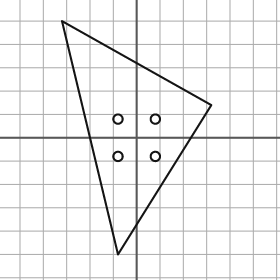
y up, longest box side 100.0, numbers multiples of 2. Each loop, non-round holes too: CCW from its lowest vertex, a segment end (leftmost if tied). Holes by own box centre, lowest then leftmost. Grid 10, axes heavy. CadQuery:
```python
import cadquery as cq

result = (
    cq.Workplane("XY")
    .moveTo(-8.0, -50.0)
    .lineTo(32.0, 14.0)
    .lineTo(-32.0, 50.0)
    .close()
    .moveTo(-8.0, -8.0)
    .circle(2.0)
    .moveTo(8.0, -8.0)
    .circle(2.0)
    .moveTo(-8.0, 8.0)
    .circle(2.0)
    .moveTo(8.0, 8.0)
    .circle(2.0)
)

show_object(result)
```